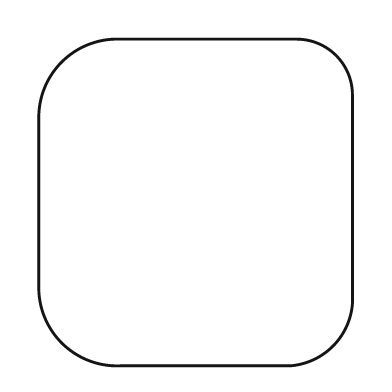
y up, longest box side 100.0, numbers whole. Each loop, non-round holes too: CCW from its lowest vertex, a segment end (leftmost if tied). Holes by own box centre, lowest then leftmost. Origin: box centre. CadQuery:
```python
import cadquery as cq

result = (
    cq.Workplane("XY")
    .moveTo(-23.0, -50.0)
    .lineTo(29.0, -50.0)
    .threePointArc((42.0, -44.0), (48.0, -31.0))
    .lineTo(48.0, 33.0)
    .threePointArc((43.0, 45.0), (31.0, 50.0))
    .lineTo(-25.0, 50.0)
    .threePointArc((-41.0, 43.0), (-48.0, 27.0))
    .lineTo(-48.0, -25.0)
    .threePointArc((-41.0, -43.0), (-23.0, -50.0))
    .close()
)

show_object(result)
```